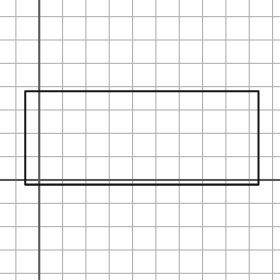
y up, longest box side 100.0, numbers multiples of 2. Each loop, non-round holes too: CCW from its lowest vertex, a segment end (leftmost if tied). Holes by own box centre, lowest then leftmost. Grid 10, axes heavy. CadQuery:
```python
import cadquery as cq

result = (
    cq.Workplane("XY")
    .moveTo(-6.0, -2.0)
    .lineTo(94.0, -2.0)
    .lineTo(94.0, 38.0)
    .lineTo(-6.0, 38.0)
    .close()
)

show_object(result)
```